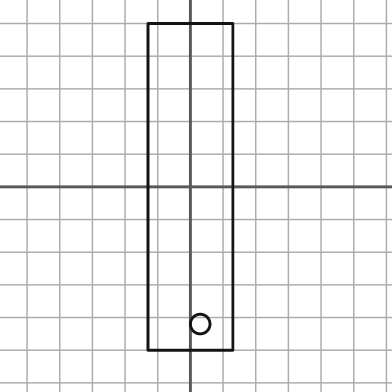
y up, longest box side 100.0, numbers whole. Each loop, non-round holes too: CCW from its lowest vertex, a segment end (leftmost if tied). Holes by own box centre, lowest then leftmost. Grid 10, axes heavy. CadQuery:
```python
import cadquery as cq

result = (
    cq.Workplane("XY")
    .moveTo(-13.0, -50.0)
    .lineTo(13.0, -50.0)
    .lineTo(13.0, 50.0)
    .lineTo(-13.0, 50.0)
    .close()
    .moveTo(3.0, -42.0)
    .circle(3.0)
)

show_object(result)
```